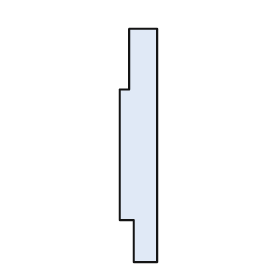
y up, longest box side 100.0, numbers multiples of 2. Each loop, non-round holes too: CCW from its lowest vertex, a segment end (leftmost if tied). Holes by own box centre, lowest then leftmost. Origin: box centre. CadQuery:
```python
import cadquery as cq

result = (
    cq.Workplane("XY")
    .moveTo(-2.0, -50.0)
    .lineTo(8.0, -50.0)
    .lineTo(8.0, 50.0)
    .lineTo(-4.0, 50.0)
    .lineTo(-4.0, 24.0)
    .lineTo(-8.0, 24.0)
    .lineTo(-8.0, -32.0)
    .lineTo(-2.0, -32.0)
    .close()
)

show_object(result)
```